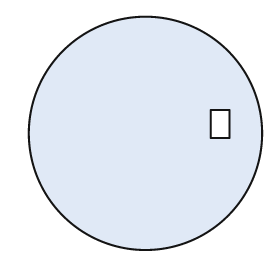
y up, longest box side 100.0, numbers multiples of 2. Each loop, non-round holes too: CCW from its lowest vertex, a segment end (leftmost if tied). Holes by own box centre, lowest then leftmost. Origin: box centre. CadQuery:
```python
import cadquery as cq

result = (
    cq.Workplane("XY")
    .moveTo(0.0, 0.0)
    .circle(50.0)
    .moveTo(28.0, -2.0)
    .lineTo(36.0, -2.0)
    .lineTo(36.0, 10.0)
    .lineTo(28.0, 10.0)
    .close()
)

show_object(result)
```